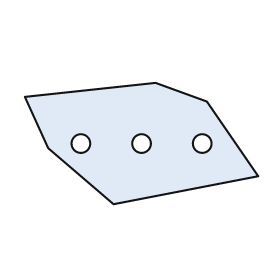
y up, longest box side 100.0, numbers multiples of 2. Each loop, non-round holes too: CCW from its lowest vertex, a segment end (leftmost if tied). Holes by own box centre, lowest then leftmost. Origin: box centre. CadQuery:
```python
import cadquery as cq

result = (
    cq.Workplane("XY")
    .moveTo(-12.0, -26.0)
    .lineTo(50.0, -14.0)
    .lineTo(28.0, 18.0)
    .lineTo(6.0, 26.0)
    .lineTo(-50.0, 20.0)
    .lineTo(-40.0, -2.0)
    .close()
    .moveTo(-26.0, 0.0)
    .circle(4.0)
    .moveTo(0.0, 0.0)
    .circle(4.0)
    .moveTo(26.0, 0.0)
    .circle(4.0)
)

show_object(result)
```